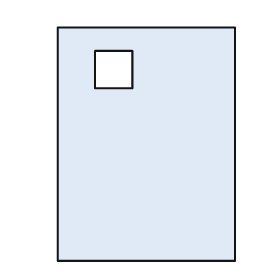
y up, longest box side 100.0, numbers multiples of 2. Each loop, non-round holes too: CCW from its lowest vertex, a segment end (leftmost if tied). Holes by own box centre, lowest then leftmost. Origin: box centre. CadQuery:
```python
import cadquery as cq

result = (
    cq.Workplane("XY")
    .moveTo(-38.0, -50.0)
    .lineTo(38.0, -50.0)
    .lineTo(38.0, 50.0)
    .lineTo(-38.0, 50.0)
    .close()
    .moveTo(-22.0, 24.0)
    .lineTo(-6.0, 24.0)
    .lineTo(-6.0, 40.0)
    .lineTo(-22.0, 40.0)
    .close()
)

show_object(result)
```